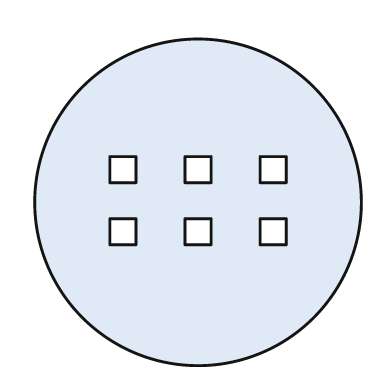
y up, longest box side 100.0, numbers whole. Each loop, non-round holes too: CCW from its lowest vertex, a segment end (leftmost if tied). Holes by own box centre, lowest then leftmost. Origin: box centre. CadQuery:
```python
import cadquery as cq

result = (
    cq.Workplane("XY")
    .moveTo(0.0, 0.0)
    .circle(50.0)
    .moveTo(-27.0, -13.0)
    .lineTo(-19.0, -13.0)
    .lineTo(-19.0, -5.0)
    .lineTo(-27.0, -5.0)
    .close()
    .moveTo(-4.0, -13.0)
    .lineTo(4.0, -13.0)
    .lineTo(4.0, -5.0)
    .lineTo(-4.0, -5.0)
    .close()
    .moveTo(19.0, -13.0)
    .lineTo(27.0, -13.0)
    .lineTo(27.0, -5.0)
    .lineTo(19.0, -5.0)
    .close()
    .moveTo(-27.0, 6.0)
    .lineTo(-19.0, 6.0)
    .lineTo(-19.0, 14.0)
    .lineTo(-27.0, 14.0)
    .close()
    .moveTo(-4.0, 6.0)
    .lineTo(4.0, 6.0)
    .lineTo(4.0, 14.0)
    .lineTo(-4.0, 14.0)
    .close()
    .moveTo(19.0, 6.0)
    .lineTo(27.0, 6.0)
    .lineTo(27.0, 14.0)
    .lineTo(19.0, 14.0)
    .close()
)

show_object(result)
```